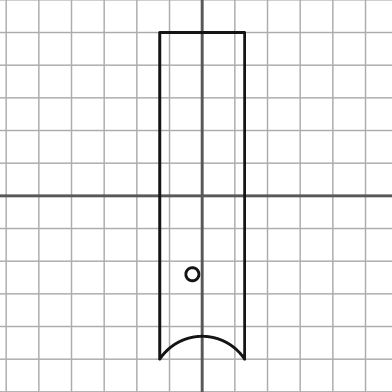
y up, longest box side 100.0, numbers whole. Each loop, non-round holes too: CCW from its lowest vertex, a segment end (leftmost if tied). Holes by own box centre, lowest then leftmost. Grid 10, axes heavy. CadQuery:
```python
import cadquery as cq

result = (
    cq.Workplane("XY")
    .moveTo(-13.0, -50.0)
    .threePointArc((0.0, -43.0), (13.0, -50.0))
    .lineTo(13.0, 50.0)
    .lineTo(-13.0, 50.0)
    .close()
    .moveTo(-3.0, -24.0)
    .circle(2.0)
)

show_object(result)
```